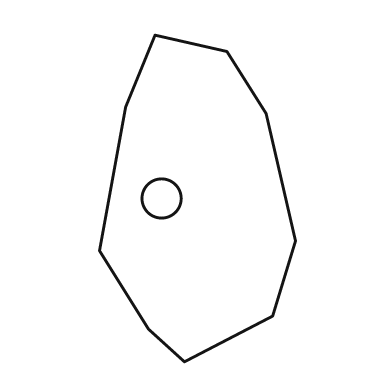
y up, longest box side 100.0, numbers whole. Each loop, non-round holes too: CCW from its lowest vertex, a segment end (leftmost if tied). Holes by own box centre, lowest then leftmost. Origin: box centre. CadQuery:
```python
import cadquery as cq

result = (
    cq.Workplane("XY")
    .moveTo(-4.0, -50.0)
    .lineTo(23.0, -36.0)
    .lineTo(30.0, -13.0)
    .lineTo(21.0, 26.0)
    .lineTo(9.0, 45.0)
    .lineTo(-13.0, 50.0)
    .lineTo(-22.0, 28.0)
    .lineTo(-30.0, -16.0)
    .lineTo(-15.0, -40.0)
    .close()
    .moveTo(-11.0, 0.0)
    .circle(6.0)
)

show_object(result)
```